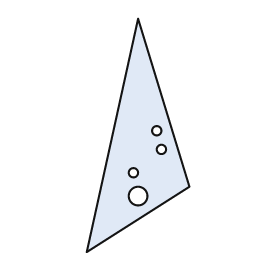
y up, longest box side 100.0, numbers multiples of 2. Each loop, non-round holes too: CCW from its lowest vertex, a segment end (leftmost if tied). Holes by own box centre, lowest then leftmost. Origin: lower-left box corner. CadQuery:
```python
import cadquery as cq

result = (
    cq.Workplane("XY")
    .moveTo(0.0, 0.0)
    .lineTo(44.0, 28.0)
    .lineTo(22.0, 100.0)
    .close()
    .moveTo(22.0, 24.0)
    .circle(4.0)
    .moveTo(20.0, 34.0)
    .circle(2.0)
    .moveTo(32.0, 44.0)
    .circle(2.0)
    .moveTo(30.0, 52.0)
    .circle(2.0)
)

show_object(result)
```